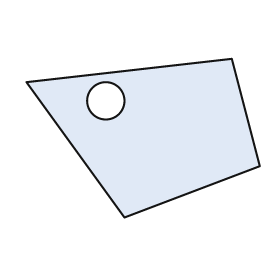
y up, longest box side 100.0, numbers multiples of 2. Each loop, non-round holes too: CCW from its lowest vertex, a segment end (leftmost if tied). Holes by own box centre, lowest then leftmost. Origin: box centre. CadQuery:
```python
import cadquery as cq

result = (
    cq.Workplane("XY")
    .moveTo(-8.0, -34.0)
    .lineTo(50.0, -12.0)
    .lineTo(38.0, 34.0)
    .lineTo(-50.0, 24.0)
    .close()
    .moveTo(-16.0, 16.0)
    .circle(8.0)
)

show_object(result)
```